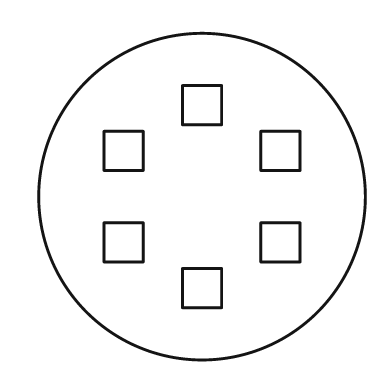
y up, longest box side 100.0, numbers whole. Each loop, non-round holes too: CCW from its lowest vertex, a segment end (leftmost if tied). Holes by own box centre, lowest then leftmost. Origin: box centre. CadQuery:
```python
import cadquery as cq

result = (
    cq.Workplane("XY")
    .moveTo(0.0, 0.0)
    .circle(50.0)
    .moveTo(-6.0, -34.0)
    .lineTo(6.0, -34.0)
    .lineTo(6.0, -22.0)
    .lineTo(-6.0, -22.0)
    .close()
    .moveTo(-30.0, -20.0)
    .lineTo(-18.0, -20.0)
    .lineTo(-18.0, -8.0)
    .lineTo(-30.0, -8.0)
    .close()
    .moveTo(18.0, -20.0)
    .lineTo(30.0, -20.0)
    .lineTo(30.0, -8.0)
    .lineTo(18.0, -8.0)
    .close()
    .moveTo(-30.0, 8.0)
    .lineTo(-18.0, 8.0)
    .lineTo(-18.0, 20.0)
    .lineTo(-30.0, 20.0)
    .close()
    .moveTo(18.0, 8.0)
    .lineTo(30.0, 8.0)
    .lineTo(30.0, 20.0)
    .lineTo(18.0, 20.0)
    .close()
    .moveTo(-6.0, 22.0)
    .lineTo(6.0, 22.0)
    .lineTo(6.0, 34.0)
    .lineTo(-6.0, 34.0)
    .close()
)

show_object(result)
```